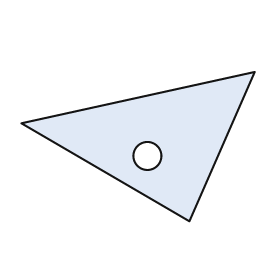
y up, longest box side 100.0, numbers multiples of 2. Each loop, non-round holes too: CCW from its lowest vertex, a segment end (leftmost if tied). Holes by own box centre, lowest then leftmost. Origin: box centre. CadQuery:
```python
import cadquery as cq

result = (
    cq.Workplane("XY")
    .moveTo(22.0, -32.0)
    .lineTo(50.0, 32.0)
    .lineTo(-50.0, 10.0)
    .close()
    .moveTo(4.0, -4.0)
    .circle(6.0)
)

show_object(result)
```